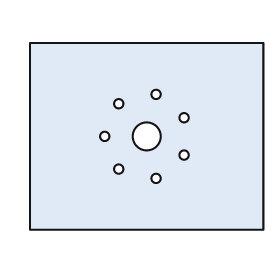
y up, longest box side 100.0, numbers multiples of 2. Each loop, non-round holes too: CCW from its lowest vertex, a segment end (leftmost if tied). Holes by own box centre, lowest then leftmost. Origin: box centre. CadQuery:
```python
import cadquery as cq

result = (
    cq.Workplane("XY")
    .moveTo(-50.0, -40.0)
    .lineTo(50.0, -40.0)
    .lineTo(50.0, 40.0)
    .lineTo(-50.0, 40.0)
    .close()
    .moveTo(4.0, -18.0)
    .circle(2.0)
    .moveTo(-12.0, -14.0)
    .circle(2.0)
    .moveTo(16.0, -8.0)
    .circle(2.0)
    .moveTo(-18.0, 0.0)
    .circle(2.0)
    .moveTo(0.0, 0.0)
    .circle(6.0)
    .moveTo(16.0, 8.0)
    .circle(2.0)
    .moveTo(-12.0, 14.0)
    .circle(2.0)
    .moveTo(4.0, 18.0)
    .circle(2.0)
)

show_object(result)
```